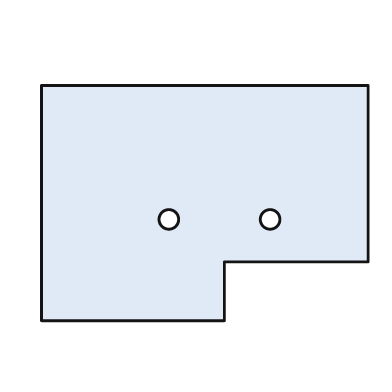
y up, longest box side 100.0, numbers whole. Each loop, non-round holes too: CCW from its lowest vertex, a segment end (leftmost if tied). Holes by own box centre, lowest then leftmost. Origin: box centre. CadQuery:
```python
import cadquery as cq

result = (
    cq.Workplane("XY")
    .moveTo(-50.0, -36.0)
    .lineTo(6.0, -36.0)
    .lineTo(6.0, -18.0)
    .lineTo(50.0, -18.0)
    .lineTo(50.0, 36.0)
    .lineTo(-50.0, 36.0)
    .close()
    .moveTo(-11.0, -5.0)
    .circle(3.0)
    .moveTo(20.0, -5.0)
    .circle(3.0)
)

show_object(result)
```